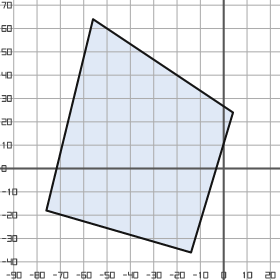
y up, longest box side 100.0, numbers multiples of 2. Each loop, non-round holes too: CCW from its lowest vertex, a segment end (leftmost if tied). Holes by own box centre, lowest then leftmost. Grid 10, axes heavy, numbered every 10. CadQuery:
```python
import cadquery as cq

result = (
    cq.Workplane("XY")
    .moveTo(-14.0, -36.0)
    .lineTo(4.0, 24.0)
    .lineTo(-56.0, 64.0)
    .lineTo(-76.0, -18.0)
    .close()
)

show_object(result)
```